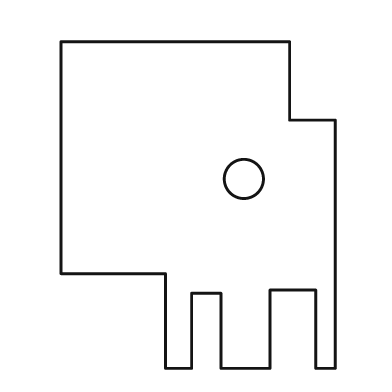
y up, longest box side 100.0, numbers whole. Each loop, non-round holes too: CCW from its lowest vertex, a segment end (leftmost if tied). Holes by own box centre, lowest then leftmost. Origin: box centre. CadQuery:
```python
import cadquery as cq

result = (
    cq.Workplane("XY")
    .moveTo(-10.0, -50.0)
    .lineTo(-2.0, -50.0)
    .lineTo(-2.0, -27.0)
    .lineTo(7.0, -27.0)
    .lineTo(7.0, -50.0)
    .lineTo(22.0, -50.0)
    .lineTo(22.0, -26.0)
    .lineTo(36.0, -26.0)
    .lineTo(36.0, -50.0)
    .lineTo(42.0, -50.0)
    .lineTo(42.0, 26.0)
    .lineTo(28.0, 26.0)
    .lineTo(28.0, 50.0)
    .lineTo(-42.0, 50.0)
    .lineTo(-42.0, -21.0)
    .lineTo(-10.0, -21.0)
    .close()
    .moveTo(14.0, 8.0)
    .circle(6.0)
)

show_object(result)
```